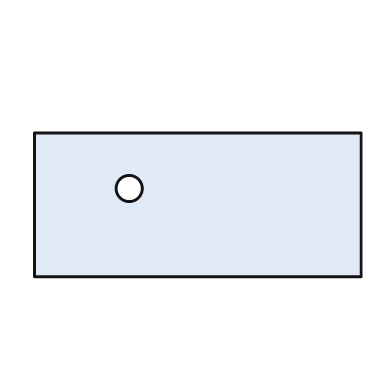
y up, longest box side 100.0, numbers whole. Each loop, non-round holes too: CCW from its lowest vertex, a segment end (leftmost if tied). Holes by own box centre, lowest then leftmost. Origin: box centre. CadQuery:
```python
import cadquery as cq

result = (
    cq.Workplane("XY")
    .moveTo(-50.0, -22.0)
    .lineTo(50.0, -22.0)
    .lineTo(50.0, 22.0)
    .lineTo(-50.0, 22.0)
    .close()
    .moveTo(-21.0, 5.0)
    .circle(4.0)
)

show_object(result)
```